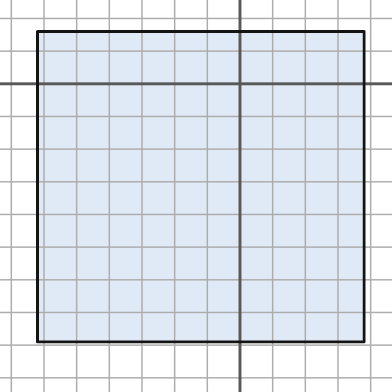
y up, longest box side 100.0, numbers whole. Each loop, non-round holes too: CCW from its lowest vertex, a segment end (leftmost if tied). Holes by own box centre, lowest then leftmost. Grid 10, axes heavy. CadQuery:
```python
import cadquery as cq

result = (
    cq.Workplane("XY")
    .moveTo(-62.0, -79.0)
    .lineTo(38.0, -79.0)
    .lineTo(38.0, 16.0)
    .lineTo(-62.0, 16.0)
    .close()
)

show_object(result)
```